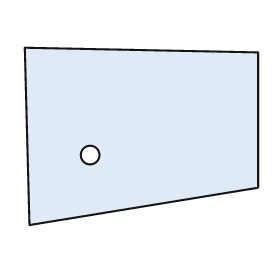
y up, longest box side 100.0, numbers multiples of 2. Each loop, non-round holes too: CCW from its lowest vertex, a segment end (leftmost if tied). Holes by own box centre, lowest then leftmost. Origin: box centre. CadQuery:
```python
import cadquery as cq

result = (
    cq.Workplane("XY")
    .moveTo(-48.0, -38.0)
    .lineTo(50.0, -22.0)
    .lineTo(50.0, 36.0)
    .lineTo(-50.0, 38.0)
    .close()
    .moveTo(-22.0, -8.0)
    .circle(4.0)
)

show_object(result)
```